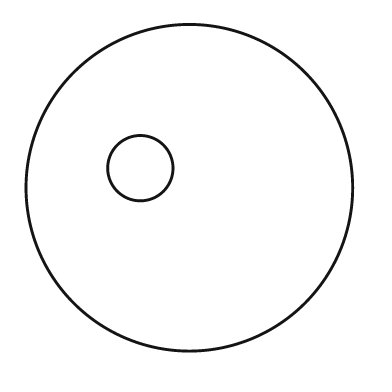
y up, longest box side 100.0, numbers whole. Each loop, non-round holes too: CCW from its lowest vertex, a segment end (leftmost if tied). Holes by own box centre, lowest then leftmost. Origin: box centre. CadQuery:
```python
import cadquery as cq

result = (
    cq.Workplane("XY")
    .moveTo(0.0, 0.0)
    .circle(50.0)
    .moveTo(-15.0, 6.0)
    .circle(10.0)
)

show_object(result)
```